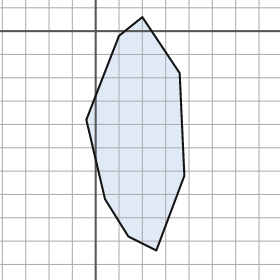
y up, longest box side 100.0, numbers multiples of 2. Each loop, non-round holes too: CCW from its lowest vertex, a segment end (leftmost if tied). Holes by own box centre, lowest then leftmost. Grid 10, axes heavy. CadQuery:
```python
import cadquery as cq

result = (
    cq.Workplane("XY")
    .moveTo(26.0, -94.0)
    .lineTo(38.0, -62.0)
    .lineTo(36.0, -18.0)
    .lineTo(20.0, 6.0)
    .lineTo(10.0, -2.0)
    .lineTo(-4.0, -38.0)
    .lineTo(4.0, -72.0)
    .lineTo(14.0, -88.0)
    .close()
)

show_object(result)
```